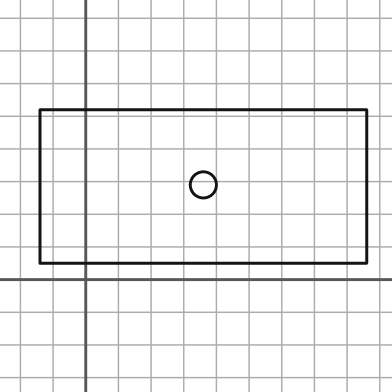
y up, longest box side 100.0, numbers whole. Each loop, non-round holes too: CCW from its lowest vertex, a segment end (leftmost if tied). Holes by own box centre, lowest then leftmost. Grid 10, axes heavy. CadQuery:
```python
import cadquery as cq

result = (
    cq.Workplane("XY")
    .moveTo(-14.0, 5.0)
    .lineTo(86.0, 5.0)
    .lineTo(86.0, 52.0)
    .lineTo(-14.0, 52.0)
    .close()
    .moveTo(36.0, 29.0)
    .circle(4.0)
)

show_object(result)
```